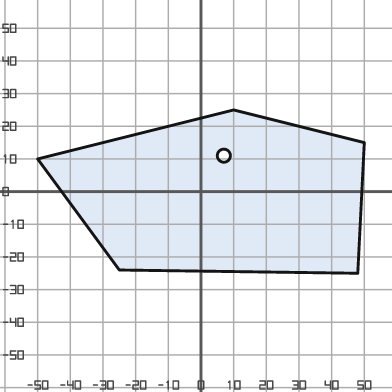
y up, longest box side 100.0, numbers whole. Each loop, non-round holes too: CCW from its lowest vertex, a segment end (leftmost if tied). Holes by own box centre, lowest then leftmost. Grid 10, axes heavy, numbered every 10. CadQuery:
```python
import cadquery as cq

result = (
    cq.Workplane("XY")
    .moveTo(48.0, -25.0)
    .lineTo(50.0, 15.0)
    .lineTo(10.0, 25.0)
    .lineTo(-50.0, 10.0)
    .lineTo(-25.0, -24.0)
    .close()
    .moveTo(7.0, 11.0)
    .circle(2.0)
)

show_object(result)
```